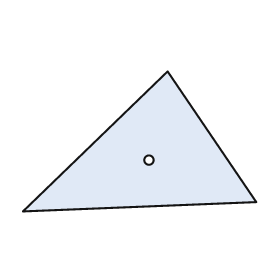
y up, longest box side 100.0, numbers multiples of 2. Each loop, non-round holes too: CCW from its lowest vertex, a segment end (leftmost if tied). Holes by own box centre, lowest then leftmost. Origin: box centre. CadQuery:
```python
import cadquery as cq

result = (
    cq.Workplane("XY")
    .moveTo(-50.0, -30.0)
    .lineTo(50.0, -26.0)
    .lineTo(12.0, 30.0)
    .close()
    .moveTo(4.0, -8.0)
    .circle(2.0)
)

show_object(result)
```